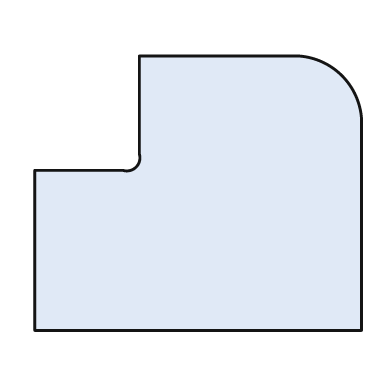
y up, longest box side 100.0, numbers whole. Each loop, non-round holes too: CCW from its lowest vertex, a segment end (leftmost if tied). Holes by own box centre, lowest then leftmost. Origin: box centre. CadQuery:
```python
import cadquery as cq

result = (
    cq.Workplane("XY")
    .moveTo(-50.0, -42.0)
    .lineTo(50.0, -42.0)
    .lineTo(50.0, 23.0)
    .threePointArc((44.0, 36.0), (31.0, 42.0))
    .lineTo(-18.0, 42.0)
    .lineTo(-18.0, 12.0)
    .threePointArc((-19.0, 8.0), (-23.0, 7.0))
    .lineTo(-50.0, 7.0)
    .close()
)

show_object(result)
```